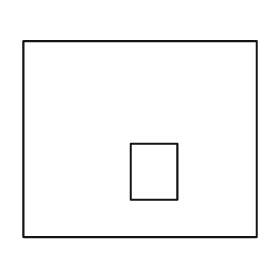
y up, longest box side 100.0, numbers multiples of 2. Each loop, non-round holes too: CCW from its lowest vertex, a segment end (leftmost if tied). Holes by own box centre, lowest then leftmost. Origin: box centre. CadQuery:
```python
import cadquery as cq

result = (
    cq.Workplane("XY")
    .moveTo(-50.0, -42.0)
    .lineTo(50.0, -42.0)
    .lineTo(50.0, 42.0)
    .lineTo(-50.0, 42.0)
    .close()
    .moveTo(-4.0, -26.0)
    .lineTo(16.0, -26.0)
    .lineTo(16.0, -2.0)
    .lineTo(-4.0, -2.0)
    .close()
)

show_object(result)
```